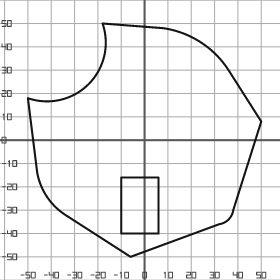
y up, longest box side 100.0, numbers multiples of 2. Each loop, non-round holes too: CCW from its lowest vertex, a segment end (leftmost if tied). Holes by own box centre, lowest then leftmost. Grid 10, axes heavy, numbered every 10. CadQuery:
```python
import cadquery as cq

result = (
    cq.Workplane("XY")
    .moveTo(-6.0, -50.0)
    .lineTo(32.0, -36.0)
    .threePointArc((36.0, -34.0), (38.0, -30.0))
    .lineTo(50.0, 8.0)
    .lineTo(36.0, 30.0)
    .threePointArc((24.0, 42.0), (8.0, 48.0))
    .lineTo(-18.0, 50.0)
    .threePointArc((-24.0, 24.0), (-50.0, 18.0))
    .lineTo(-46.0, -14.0)
    .threePointArc((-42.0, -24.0), (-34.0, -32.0))
    .close()
    .moveTo(-10.0, -40.0)
    .lineTo(6.0, -40.0)
    .lineTo(6.0, -16.0)
    .lineTo(-10.0, -16.0)
    .close()
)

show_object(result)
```